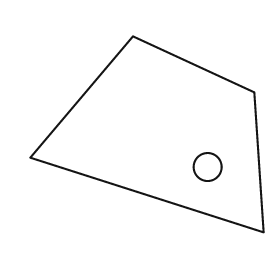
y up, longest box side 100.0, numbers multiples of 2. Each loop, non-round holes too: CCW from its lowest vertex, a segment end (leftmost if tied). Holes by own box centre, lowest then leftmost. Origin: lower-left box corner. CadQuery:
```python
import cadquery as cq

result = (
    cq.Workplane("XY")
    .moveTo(100.0, 0.0)
    .lineTo(96.0, 60.0)
    .lineTo(44.0, 84.0)
    .lineTo(0.0, 32.0)
    .close()
    .moveTo(76.0, 28.0)
    .circle(6.0)
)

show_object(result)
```